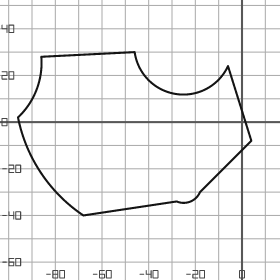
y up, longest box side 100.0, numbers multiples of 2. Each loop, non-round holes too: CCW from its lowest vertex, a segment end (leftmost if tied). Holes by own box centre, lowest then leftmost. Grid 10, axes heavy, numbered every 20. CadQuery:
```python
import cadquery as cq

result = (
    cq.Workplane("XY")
    .moveTo(-68.0, -40.0)
    .lineTo(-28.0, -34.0)
    .threePointArc((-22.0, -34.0), (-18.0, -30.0))
    .lineTo(4.0, -8.0)
    .lineTo(-6.0, 24.0)
    .threePointArc((-28.0, 12.0), (-46.0, 30.0))
    .lineTo(-86.0, 28.0)
    .threePointArc((-88.0, 14.0), (-96.0, 2.0))
    .threePointArc((-86.0, -22.0), (-68.0, -40.0))
    .close()
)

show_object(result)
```